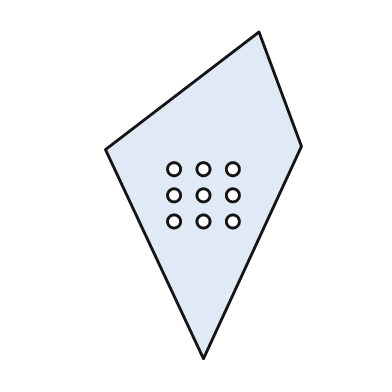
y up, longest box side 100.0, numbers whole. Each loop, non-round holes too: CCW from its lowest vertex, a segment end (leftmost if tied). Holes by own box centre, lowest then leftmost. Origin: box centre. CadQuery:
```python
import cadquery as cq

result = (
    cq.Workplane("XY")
    .moveTo(0.0, -50.0)
    .lineTo(30.0, 15.0)
    .lineTo(17.0, 50.0)
    .lineTo(-30.0, 14.0)
    .close()
    .moveTo(-9.0, -8.0)
    .circle(2.0)
    .moveTo(0.0, -8.0)
    .circle(2.0)
    .moveTo(9.0, -8.0)
    .circle(2.0)
    .moveTo(-9.0, 0.0)
    .circle(2.0)
    .moveTo(0.0, 0.0)
    .circle(2.0)
    .moveTo(9.0, 0.0)
    .circle(2.0)
    .moveTo(-9.0, 8.0)
    .circle(2.0)
    .moveTo(0.0, 8.0)
    .circle(2.0)
    .moveTo(9.0, 8.0)
    .circle(2.0)
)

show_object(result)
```